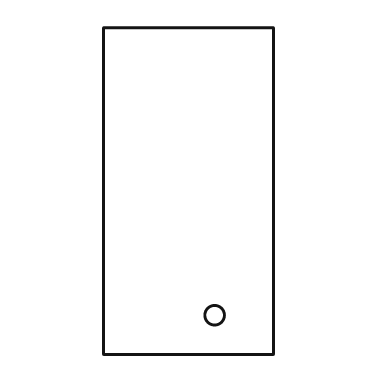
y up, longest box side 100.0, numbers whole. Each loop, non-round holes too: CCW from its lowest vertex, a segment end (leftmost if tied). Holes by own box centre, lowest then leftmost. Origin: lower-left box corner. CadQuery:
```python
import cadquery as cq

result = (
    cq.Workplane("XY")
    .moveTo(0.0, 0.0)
    .lineTo(52.0, 0.0)
    .lineTo(52.0, 100.0)
    .lineTo(0.0, 100.0)
    .close()
    .moveTo(34.0, 12.0)
    .circle(3.0)
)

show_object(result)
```